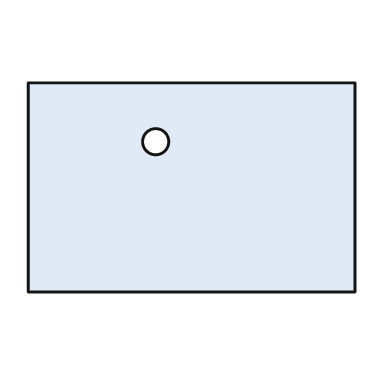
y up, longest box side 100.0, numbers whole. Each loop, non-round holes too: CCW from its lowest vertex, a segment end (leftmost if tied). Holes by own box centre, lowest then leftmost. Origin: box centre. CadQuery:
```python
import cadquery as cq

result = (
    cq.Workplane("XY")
    .moveTo(-50.0, -32.0)
    .lineTo(50.0, -32.0)
    .lineTo(50.0, 32.0)
    .lineTo(-50.0, 32.0)
    .close()
    .moveTo(-11.0, 14.0)
    .circle(4.0)
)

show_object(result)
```